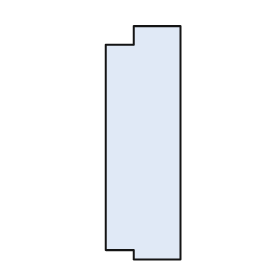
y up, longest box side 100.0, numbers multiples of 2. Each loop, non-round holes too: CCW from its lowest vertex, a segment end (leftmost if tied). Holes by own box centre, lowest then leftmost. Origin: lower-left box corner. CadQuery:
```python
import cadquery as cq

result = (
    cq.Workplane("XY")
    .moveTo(12.0, 0.0)
    .lineTo(32.0, 0.0)
    .lineTo(32.0, 100.0)
    .lineTo(12.0, 100.0)
    .lineTo(12.0, 92.0)
    .lineTo(0.0, 92.0)
    .lineTo(0.0, 4.0)
    .lineTo(12.0, 4.0)
    .close()
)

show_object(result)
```